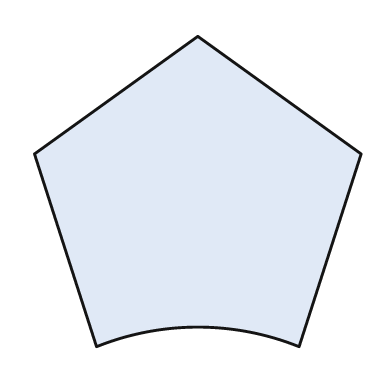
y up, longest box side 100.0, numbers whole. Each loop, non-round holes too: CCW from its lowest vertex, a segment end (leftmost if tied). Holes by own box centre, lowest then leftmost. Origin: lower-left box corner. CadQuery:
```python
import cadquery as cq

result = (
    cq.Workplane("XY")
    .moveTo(19.0, 0.0)
    .threePointArc((50.0, 6.0), (81.0, 0.0))
    .lineTo(100.0, 59.0)
    .lineTo(50.0, 95.0)
    .lineTo(0.0, 59.0)
    .close()
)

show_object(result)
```